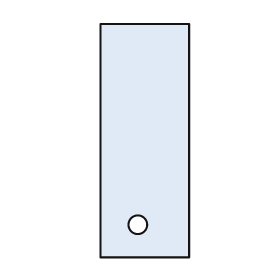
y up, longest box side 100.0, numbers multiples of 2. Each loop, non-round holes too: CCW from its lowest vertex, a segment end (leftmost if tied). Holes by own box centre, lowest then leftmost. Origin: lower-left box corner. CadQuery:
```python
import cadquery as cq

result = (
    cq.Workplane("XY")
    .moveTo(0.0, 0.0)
    .lineTo(38.0, 0.0)
    .lineTo(38.0, 100.0)
    .lineTo(0.0, 100.0)
    .close()
    .moveTo(16.0, 14.0)
    .circle(4.0)
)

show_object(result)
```